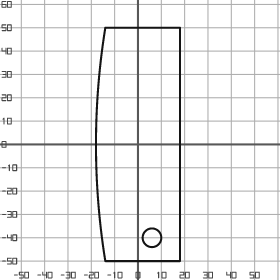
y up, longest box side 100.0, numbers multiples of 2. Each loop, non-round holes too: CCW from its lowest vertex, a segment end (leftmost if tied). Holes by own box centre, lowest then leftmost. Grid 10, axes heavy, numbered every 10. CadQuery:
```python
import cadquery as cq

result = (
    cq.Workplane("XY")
    .moveTo(-14.0, -50.0)
    .lineTo(18.0, -50.0)
    .lineTo(18.0, 50.0)
    .lineTo(-14.0, 50.0)
    .threePointArc((-18.0, 0.0), (-14.0, -50.0))
    .close()
    .moveTo(6.0, -40.0)
    .circle(4.0)
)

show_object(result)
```